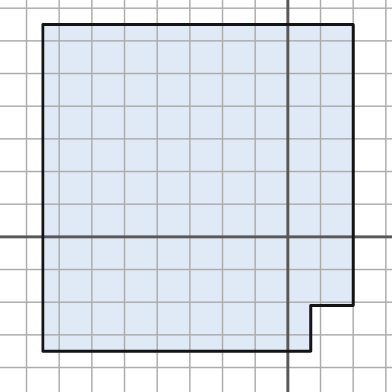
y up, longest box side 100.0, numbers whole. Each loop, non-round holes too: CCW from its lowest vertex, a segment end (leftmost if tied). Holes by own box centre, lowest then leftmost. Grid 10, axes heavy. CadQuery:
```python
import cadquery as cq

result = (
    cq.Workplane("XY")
    .moveTo(-75.0, -35.0)
    .lineTo(7.0, -35.0)
    .lineTo(7.0, -21.0)
    .lineTo(20.0, -21.0)
    .lineTo(20.0, 65.0)
    .lineTo(-75.0, 65.0)
    .close()
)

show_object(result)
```